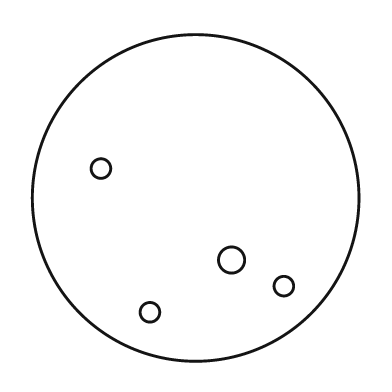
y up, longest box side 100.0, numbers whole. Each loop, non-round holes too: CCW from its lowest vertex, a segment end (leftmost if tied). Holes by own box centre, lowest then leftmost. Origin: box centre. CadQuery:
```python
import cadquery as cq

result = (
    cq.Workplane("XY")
    .moveTo(0.0, 0.0)
    .circle(50.0)
    .moveTo(-14.0, -35.0)
    .circle(3.0)
    .moveTo(27.0, -27.0)
    .circle(3.0)
    .moveTo(11.0, -19.0)
    .circle(4.0)
    .moveTo(-29.0, 9.0)
    .circle(3.0)
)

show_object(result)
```